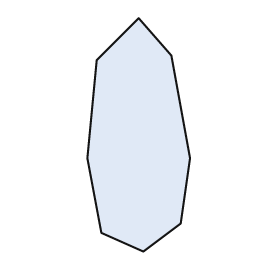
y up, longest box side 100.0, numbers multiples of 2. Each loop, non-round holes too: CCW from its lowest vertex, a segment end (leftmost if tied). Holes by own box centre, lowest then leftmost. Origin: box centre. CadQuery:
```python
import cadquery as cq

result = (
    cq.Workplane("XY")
    .moveTo(2.0, -50.0)
    .lineTo(18.0, -38.0)
    .lineTo(22.0, -10.0)
    .lineTo(14.0, 34.0)
    .lineTo(0.0, 50.0)
    .lineTo(-18.0, 32.0)
    .lineTo(-22.0, -10.0)
    .lineTo(-16.0, -42.0)
    .close()
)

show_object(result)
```